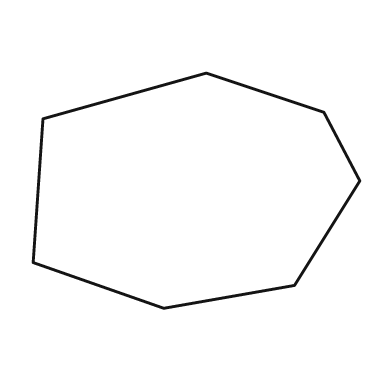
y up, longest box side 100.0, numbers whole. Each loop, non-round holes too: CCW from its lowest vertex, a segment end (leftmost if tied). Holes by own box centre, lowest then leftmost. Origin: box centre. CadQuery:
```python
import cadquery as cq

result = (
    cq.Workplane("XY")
    .moveTo(-10.0, -36.0)
    .lineTo(30.0, -29.0)
    .lineTo(50.0, 3.0)
    .lineTo(39.0, 24.0)
    .lineTo(3.0, 36.0)
    .lineTo(-47.0, 22.0)
    .lineTo(-50.0, -22.0)
    .close()
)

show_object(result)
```